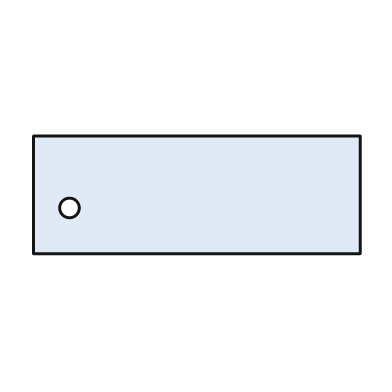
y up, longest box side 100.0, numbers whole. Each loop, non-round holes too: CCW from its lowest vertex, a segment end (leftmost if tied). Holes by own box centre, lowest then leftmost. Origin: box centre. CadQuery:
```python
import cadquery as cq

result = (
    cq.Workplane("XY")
    .moveTo(-50.0, -18.0)
    .lineTo(50.0, -18.0)
    .lineTo(50.0, 18.0)
    .lineTo(-50.0, 18.0)
    .close()
    .moveTo(-39.0, -4.0)
    .circle(3.0)
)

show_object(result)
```